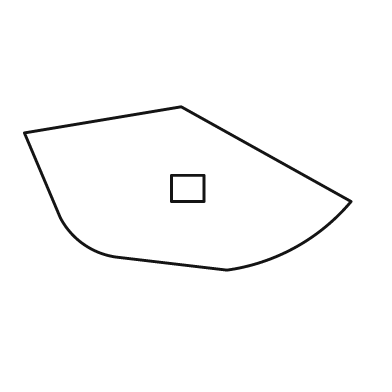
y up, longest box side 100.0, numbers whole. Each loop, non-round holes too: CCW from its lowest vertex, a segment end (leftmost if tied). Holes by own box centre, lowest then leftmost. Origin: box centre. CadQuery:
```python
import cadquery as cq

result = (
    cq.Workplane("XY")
    .moveTo(12.0, -25.0)
    .threePointArc((33.0, -18.0), (50.0, -4.0))
    .lineTo(-2.0, 25.0)
    .lineTo(-50.0, 17.0)
    .lineTo(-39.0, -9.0)
    .threePointArc((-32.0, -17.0), (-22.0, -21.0))
    .close()
    .moveTo(-5.0, -4.0)
    .lineTo(5.0, -4.0)
    .lineTo(5.0, 4.0)
    .lineTo(-5.0, 4.0)
    .close()
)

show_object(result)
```